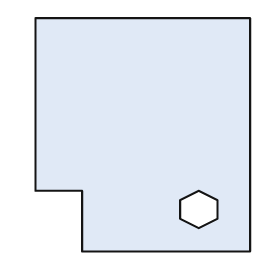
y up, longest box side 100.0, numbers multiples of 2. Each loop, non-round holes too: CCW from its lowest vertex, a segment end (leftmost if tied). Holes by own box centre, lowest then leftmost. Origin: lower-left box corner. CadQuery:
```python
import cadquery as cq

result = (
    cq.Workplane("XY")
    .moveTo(20.0, 0.0)
    .lineTo(92.0, 0.0)
    .lineTo(92.0, 100.0)
    .lineTo(0.0, 100.0)
    .lineTo(0.0, 26.0)
    .lineTo(20.0, 26.0)
    .close()
    .moveTo(70.0, 10.0)
    .lineTo(78.0, 14.0)
    .lineTo(78.0, 22.0)
    .lineTo(70.0, 26.0)
    .lineTo(62.0, 22.0)
    .lineTo(62.0, 14.0)
    .close()
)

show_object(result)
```